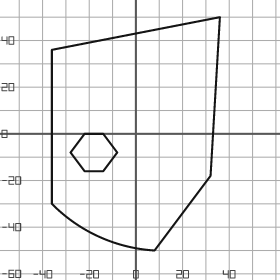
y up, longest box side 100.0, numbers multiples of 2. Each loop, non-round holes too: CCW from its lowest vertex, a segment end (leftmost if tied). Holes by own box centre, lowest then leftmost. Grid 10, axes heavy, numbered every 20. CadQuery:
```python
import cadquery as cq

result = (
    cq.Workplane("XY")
    .moveTo(8.0, -50.0)
    .lineTo(32.0, -18.0)
    .lineTo(36.0, 50.0)
    .lineTo(-36.0, 36.0)
    .lineTo(-36.0, -30.0)
    .threePointArc((-16.0, -44.0), (8.0, -50.0))
    .close()
    .moveTo(-22.0, -16.0)
    .lineTo(-14.0, -16.0)
    .lineTo(-8.0, -8.0)
    .lineTo(-14.0, 0.0)
    .lineTo(-22.0, 0.0)
    .lineTo(-28.0, -8.0)
    .close()
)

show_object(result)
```